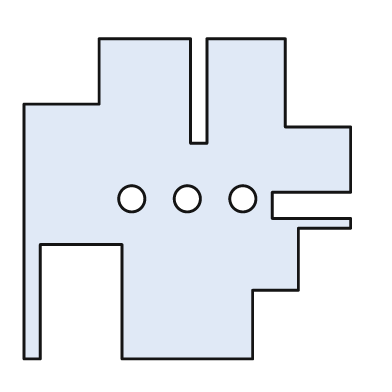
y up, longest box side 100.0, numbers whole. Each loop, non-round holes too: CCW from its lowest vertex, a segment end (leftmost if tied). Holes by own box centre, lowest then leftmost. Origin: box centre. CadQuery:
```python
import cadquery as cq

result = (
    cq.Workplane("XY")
    .moveTo(-50.0, -49.0)
    .lineTo(-45.0, -49.0)
    .lineTo(-45.0, -14.0)
    .lineTo(-20.0, -14.0)
    .lineTo(-20.0, -49.0)
    .lineTo(20.0, -49.0)
    .lineTo(20.0, -28.0)
    .lineTo(34.0, -28.0)
    .lineTo(34.0, -9.0)
    .lineTo(50.0, -9.0)
    .lineTo(50.0, -6.0)
    .lineTo(26.0, -6.0)
    .lineTo(26.0, 2.0)
    .lineTo(50.0, 2.0)
    .lineTo(50.0, 22.0)
    .lineTo(30.0, 22.0)
    .lineTo(30.0, 49.0)
    .lineTo(6.0, 49.0)
    .lineTo(6.0, 17.0)
    .lineTo(1.0, 17.0)
    .lineTo(1.0, 49.0)
    .lineTo(-27.0, 49.0)
    .lineTo(-27.0, 29.0)
    .lineTo(-50.0, 29.0)
    .close()
    .moveTo(-17.0, 0.0)
    .circle(4.0)
    .moveTo(0.0, 0.0)
    .circle(4.0)
    .moveTo(17.0, 0.0)
    .circle(4.0)
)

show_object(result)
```